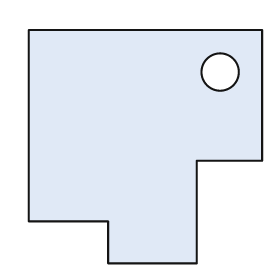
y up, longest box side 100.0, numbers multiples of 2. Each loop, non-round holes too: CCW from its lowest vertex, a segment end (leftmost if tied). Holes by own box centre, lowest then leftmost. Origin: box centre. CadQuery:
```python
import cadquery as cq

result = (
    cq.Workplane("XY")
    .moveTo(-16.0, -50.0)
    .lineTo(22.0, -50.0)
    .lineTo(22.0, -6.0)
    .lineTo(50.0, -6.0)
    .lineTo(50.0, 50.0)
    .lineTo(-50.0, 50.0)
    .lineTo(-50.0, -32.0)
    .lineTo(-16.0, -32.0)
    .close()
    .moveTo(32.0, 32.0)
    .circle(8.0)
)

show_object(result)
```